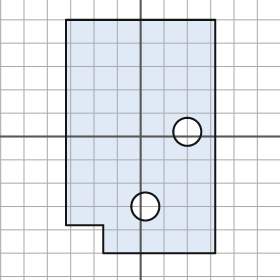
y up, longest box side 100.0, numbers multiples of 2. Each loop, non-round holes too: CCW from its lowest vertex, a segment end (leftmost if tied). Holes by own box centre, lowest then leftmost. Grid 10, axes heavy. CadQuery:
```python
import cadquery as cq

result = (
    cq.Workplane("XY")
    .moveTo(-16.0, -50.0)
    .lineTo(32.0, -50.0)
    .lineTo(32.0, 50.0)
    .lineTo(-32.0, 50.0)
    .lineTo(-32.0, -38.0)
    .lineTo(-16.0, -38.0)
    .close()
    .moveTo(2.0, -30.0)
    .circle(6.0)
    .moveTo(20.0, 2.0)
    .circle(6.0)
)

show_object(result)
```